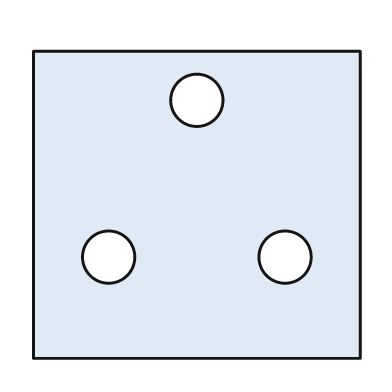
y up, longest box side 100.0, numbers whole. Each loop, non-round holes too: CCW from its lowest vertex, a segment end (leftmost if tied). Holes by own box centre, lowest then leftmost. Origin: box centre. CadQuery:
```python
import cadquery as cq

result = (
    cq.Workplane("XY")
    .moveTo(-50.0, -47.0)
    .lineTo(50.0, -47.0)
    .lineTo(50.0, 47.0)
    .lineTo(-50.0, 47.0)
    .close()
    .moveTo(-27.0, -16.0)
    .circle(8.0)
    .moveTo(27.0, -16.0)
    .circle(8.0)
    .moveTo(0.0, 32.0)
    .circle(8.0)
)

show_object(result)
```